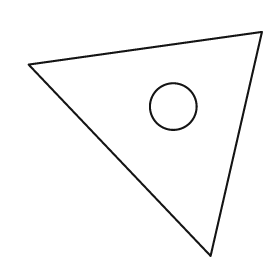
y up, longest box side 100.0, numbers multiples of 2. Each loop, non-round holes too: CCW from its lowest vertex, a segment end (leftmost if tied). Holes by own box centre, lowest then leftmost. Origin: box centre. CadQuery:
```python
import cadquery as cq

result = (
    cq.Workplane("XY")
    .moveTo(28.0, -48.0)
    .lineTo(50.0, 48.0)
    .lineTo(-50.0, 34.0)
    .close()
    .moveTo(12.0, 16.0)
    .circle(10.0)
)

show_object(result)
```